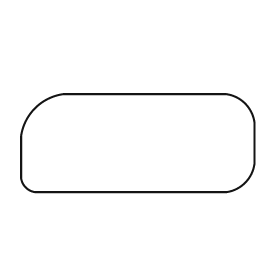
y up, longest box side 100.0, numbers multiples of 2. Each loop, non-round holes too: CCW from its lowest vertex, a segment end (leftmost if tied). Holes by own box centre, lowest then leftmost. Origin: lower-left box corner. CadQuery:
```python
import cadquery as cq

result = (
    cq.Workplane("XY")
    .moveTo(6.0, 0.0)
    .lineTo(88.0, 0.0)
    .threePointArc((96.0, 4.0), (100.0, 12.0))
    .lineTo(100.0, 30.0)
    .threePointArc((96.0, 38.0), (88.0, 42.0))
    .lineTo(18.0, 42.0)
    .threePointArc((6.0, 36.0), (0.0, 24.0))
    .lineTo(0.0, 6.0)
    .threePointArc((2.0, 2.0), (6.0, 0.0))
    .close()
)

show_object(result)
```